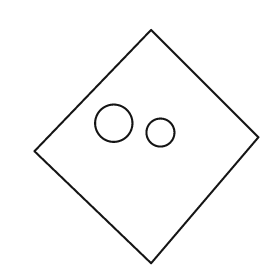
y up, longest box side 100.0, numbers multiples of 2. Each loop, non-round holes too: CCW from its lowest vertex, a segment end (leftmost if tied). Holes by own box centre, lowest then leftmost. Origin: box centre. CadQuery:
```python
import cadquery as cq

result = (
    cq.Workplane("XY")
    .moveTo(2.0, -50.0)
    .lineTo(48.0, 4.0)
    .lineTo(2.0, 50.0)
    .lineTo(-48.0, -2.0)
    .close()
    .moveTo(6.0, 6.0)
    .circle(6.0)
    .moveTo(-14.0, 10.0)
    .circle(8.0)
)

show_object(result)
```